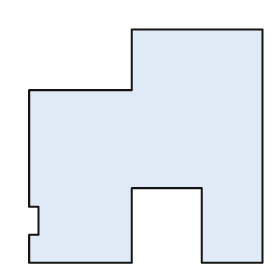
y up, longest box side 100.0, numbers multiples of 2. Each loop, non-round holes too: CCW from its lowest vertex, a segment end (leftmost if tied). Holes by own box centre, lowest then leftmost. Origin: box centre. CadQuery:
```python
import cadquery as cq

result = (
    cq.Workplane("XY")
    .moveTo(-50.0, -50.0)
    .lineTo(-6.0, -50.0)
    .lineTo(-6.0, -18.0)
    .lineTo(24.0, -18.0)
    .lineTo(24.0, -50.0)
    .lineTo(50.0, -50.0)
    .lineTo(50.0, 50.0)
    .lineTo(-6.0, 50.0)
    .lineTo(-6.0, 24.0)
    .lineTo(-50.0, 24.0)
    .lineTo(-50.0, -26.0)
    .lineTo(-46.0, -26.0)
    .lineTo(-46.0, -38.0)
    .lineTo(-50.0, -38.0)
    .close()
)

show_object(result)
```